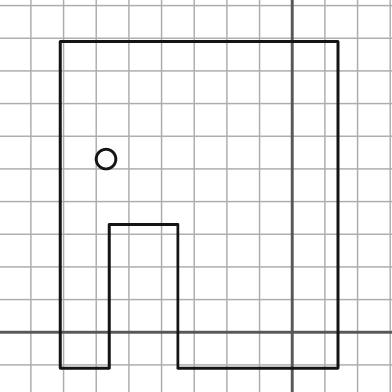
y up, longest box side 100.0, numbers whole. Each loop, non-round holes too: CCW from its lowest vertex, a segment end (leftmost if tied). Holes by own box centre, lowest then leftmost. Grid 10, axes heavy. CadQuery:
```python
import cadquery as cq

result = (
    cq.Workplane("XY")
    .moveTo(-71.0, -11.0)
    .lineTo(-56.0, -11.0)
    .lineTo(-56.0, 33.0)
    .lineTo(-35.0, 33.0)
    .lineTo(-35.0, -11.0)
    .lineTo(14.0, -11.0)
    .lineTo(14.0, 89.0)
    .lineTo(-71.0, 89.0)
    .close()
    .moveTo(-57.0, 53.0)
    .circle(3.0)
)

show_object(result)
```